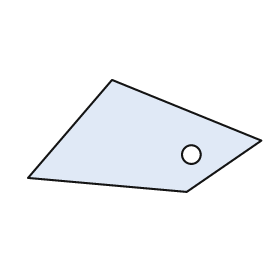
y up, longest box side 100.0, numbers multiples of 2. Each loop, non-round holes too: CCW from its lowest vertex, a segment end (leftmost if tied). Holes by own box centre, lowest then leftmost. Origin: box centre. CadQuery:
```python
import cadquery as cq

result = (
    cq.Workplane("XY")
    .moveTo(18.0, -24.0)
    .lineTo(50.0, -2.0)
    .lineTo(-14.0, 24.0)
    .lineTo(-50.0, -18.0)
    .close()
    .moveTo(20.0, -8.0)
    .circle(4.0)
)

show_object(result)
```